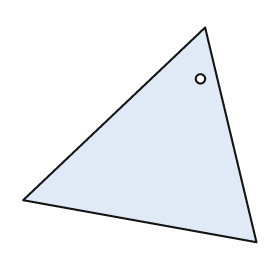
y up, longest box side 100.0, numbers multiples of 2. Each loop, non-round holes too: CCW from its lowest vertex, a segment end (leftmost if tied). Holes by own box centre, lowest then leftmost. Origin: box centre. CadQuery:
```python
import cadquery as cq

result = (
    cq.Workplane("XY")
    .moveTo(50.0, -46.0)
    .lineTo(28.0, 46.0)
    .lineTo(-50.0, -28.0)
    .close()
    .moveTo(26.0, 24.0)
    .circle(2.0)
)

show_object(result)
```